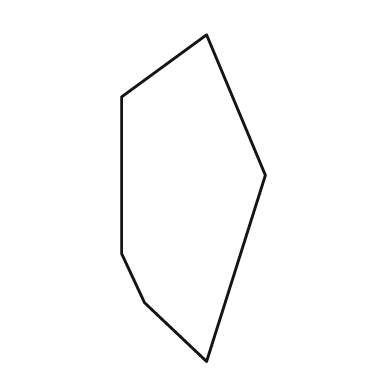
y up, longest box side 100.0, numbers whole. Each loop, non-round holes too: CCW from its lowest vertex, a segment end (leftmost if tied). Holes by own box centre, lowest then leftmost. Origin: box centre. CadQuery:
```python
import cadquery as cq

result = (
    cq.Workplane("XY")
    .moveTo(4.0, -50.0)
    .lineTo(22.0, 7.0)
    .lineTo(4.0, 50.0)
    .lineTo(-22.0, 31.0)
    .lineTo(-22.0, -17.0)
    .lineTo(-15.0, -32.0)
    .close()
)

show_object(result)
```